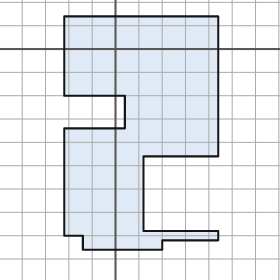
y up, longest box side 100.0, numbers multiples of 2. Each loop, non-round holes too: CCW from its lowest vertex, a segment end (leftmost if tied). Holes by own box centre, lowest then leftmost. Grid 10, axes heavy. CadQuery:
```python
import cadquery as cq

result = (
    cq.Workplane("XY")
    .moveTo(-14.0, -86.0)
    .lineTo(20.0, -86.0)
    .lineTo(20.0, -82.0)
    .lineTo(44.0, -82.0)
    .lineTo(44.0, -78.0)
    .lineTo(12.0, -78.0)
    .lineTo(12.0, -46.0)
    .lineTo(44.0, -46.0)
    .lineTo(44.0, 14.0)
    .lineTo(-22.0, 14.0)
    .lineTo(-22.0, -20.0)
    .lineTo(4.0, -20.0)
    .lineTo(4.0, -34.0)
    .lineTo(-22.0, -34.0)
    .lineTo(-22.0, -80.0)
    .lineTo(-14.0, -80.0)
    .close()
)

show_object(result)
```